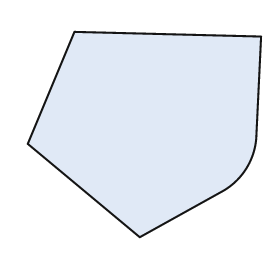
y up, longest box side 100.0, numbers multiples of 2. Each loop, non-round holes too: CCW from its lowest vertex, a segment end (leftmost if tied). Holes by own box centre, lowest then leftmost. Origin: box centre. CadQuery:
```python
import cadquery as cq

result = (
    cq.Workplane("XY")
    .moveTo(-2.0, -44.0)
    .lineTo(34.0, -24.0)
    .threePointArc((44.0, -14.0), (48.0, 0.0))
    .lineTo(50.0, 42.0)
    .lineTo(-30.0, 44.0)
    .lineTo(-50.0, -4.0)
    .close()
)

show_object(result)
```